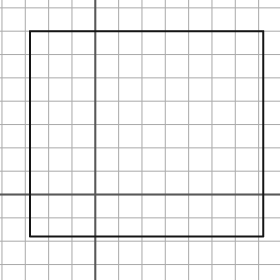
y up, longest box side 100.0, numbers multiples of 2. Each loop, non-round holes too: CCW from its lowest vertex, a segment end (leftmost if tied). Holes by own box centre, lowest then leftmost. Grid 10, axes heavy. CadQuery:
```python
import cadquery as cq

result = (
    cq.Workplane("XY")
    .moveTo(-28.0, -18.0)
    .lineTo(72.0, -18.0)
    .lineTo(72.0, 70.0)
    .lineTo(-28.0, 70.0)
    .close()
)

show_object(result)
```